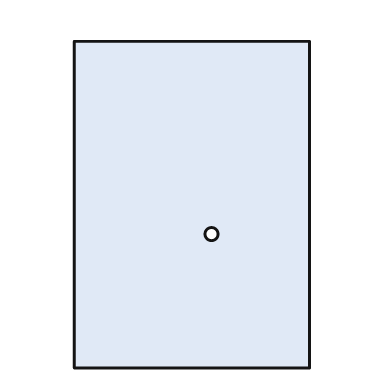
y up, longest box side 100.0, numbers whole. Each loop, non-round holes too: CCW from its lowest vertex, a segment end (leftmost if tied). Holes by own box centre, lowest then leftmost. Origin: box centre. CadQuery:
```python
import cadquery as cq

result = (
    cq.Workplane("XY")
    .moveTo(-36.0, -50.0)
    .lineTo(36.0, -50.0)
    .lineTo(36.0, 50.0)
    .lineTo(-36.0, 50.0)
    .close()
    .moveTo(6.0, -9.0)
    .circle(2.0)
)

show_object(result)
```